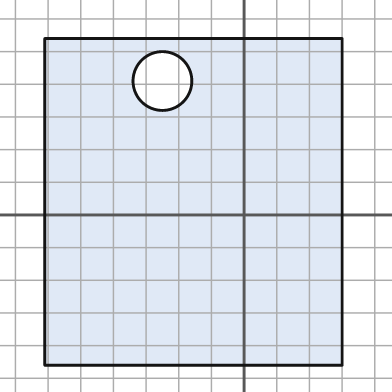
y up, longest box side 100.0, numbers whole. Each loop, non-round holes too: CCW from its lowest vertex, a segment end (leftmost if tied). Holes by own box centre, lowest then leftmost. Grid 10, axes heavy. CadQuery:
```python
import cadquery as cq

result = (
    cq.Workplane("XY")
    .moveTo(-61.0, -46.0)
    .lineTo(30.0, -46.0)
    .lineTo(30.0, 54.0)
    .lineTo(-61.0, 54.0)
    .close()
    .moveTo(-25.0, 41.0)
    .circle(9.0)
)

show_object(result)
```